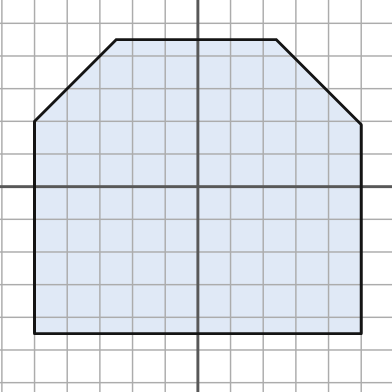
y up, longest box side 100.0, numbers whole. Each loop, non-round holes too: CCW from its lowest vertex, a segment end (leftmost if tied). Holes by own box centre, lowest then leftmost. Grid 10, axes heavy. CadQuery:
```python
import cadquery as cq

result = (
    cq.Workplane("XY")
    .moveTo(-50.0, -45.0)
    .lineTo(50.0, -45.0)
    .lineTo(50.0, 19.0)
    .lineTo(24.0, 45.0)
    .lineTo(-25.0, 45.0)
    .lineTo(-50.0, 20.0)
    .close()
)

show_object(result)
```